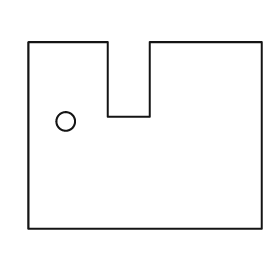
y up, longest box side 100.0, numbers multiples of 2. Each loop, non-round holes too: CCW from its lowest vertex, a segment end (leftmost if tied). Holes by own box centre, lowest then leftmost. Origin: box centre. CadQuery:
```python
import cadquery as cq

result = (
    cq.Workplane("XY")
    .moveTo(-50.0, -40.0)
    .lineTo(50.0, -40.0)
    .lineTo(50.0, 40.0)
    .lineTo(2.0, 40.0)
    .lineTo(2.0, 8.0)
    .lineTo(-16.0, 8.0)
    .lineTo(-16.0, 40.0)
    .lineTo(-50.0, 40.0)
    .close()
    .moveTo(-34.0, 6.0)
    .circle(4.0)
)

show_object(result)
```